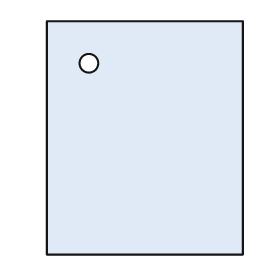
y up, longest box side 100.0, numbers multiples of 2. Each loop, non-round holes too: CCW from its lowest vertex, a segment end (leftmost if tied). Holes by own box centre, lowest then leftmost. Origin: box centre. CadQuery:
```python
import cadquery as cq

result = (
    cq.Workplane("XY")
    .moveTo(-42.0, -50.0)
    .lineTo(42.0, -50.0)
    .lineTo(42.0, 50.0)
    .lineTo(-42.0, 50.0)
    .close()
    .moveTo(-24.0, 32.0)
    .circle(4.0)
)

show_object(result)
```